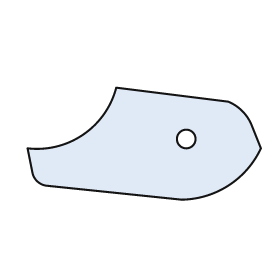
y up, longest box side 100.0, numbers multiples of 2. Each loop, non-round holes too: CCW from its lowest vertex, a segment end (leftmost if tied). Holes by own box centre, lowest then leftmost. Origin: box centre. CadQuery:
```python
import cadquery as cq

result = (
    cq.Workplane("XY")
    .moveTo(16.0, -24.0)
    .threePointArc((36.0, -18.0), (50.0, -2.0))
    .lineTo(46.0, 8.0)
    .threePointArc((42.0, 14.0), (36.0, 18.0))
    .lineTo(-12.0, 24.0)
    .threePointArc((-26.0, 4.0), (-50.0, -2.0))
    .lineTo(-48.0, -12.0)
    .threePointArc((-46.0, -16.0), (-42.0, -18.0))
    .close()
    .moveTo(18.0, 2.0)
    .circle(4.0)
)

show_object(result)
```